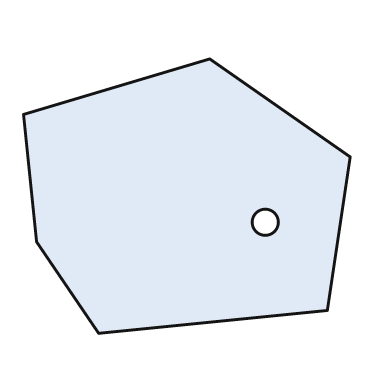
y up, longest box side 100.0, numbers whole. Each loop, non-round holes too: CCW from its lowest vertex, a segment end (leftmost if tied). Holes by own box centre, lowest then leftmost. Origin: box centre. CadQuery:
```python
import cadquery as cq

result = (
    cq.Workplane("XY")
    .moveTo(-27.0, -42.0)
    .lineTo(43.0, -35.0)
    .lineTo(50.0, 12.0)
    .lineTo(7.0, 42.0)
    .lineTo(-50.0, 25.0)
    .lineTo(-46.0, -14.0)
    .close()
    .moveTo(24.0, -8.0)
    .circle(4.0)
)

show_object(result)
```